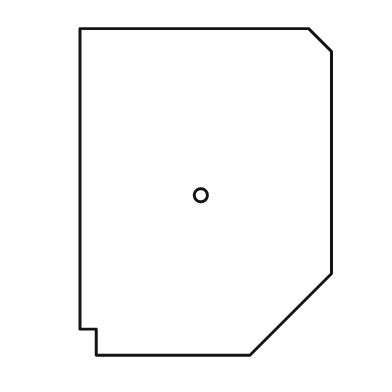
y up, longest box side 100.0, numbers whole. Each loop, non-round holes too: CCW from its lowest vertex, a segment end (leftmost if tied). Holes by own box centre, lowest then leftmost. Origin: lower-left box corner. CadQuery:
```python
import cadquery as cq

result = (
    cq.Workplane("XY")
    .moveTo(5.0, 0.0)
    .lineTo(52.0, 0.0)
    .lineTo(77.0, 25.0)
    .lineTo(77.0, 93.0)
    .lineTo(70.0, 100.0)
    .lineTo(0.0, 100.0)
    .lineTo(0.0, 8.0)
    .lineTo(5.0, 8.0)
    .close()
    .moveTo(37.0, 49.0)
    .circle(2.0)
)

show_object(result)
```